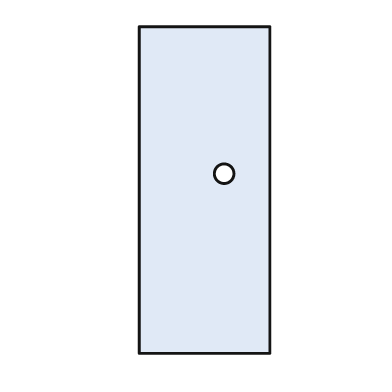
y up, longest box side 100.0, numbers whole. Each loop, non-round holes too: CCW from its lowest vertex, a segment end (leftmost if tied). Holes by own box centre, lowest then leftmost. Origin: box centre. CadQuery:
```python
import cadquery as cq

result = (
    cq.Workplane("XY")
    .moveTo(-20.0, -50.0)
    .lineTo(20.0, -50.0)
    .lineTo(20.0, 50.0)
    .lineTo(-20.0, 50.0)
    .close()
    .moveTo(6.0, 5.0)
    .circle(3.0)
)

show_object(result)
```